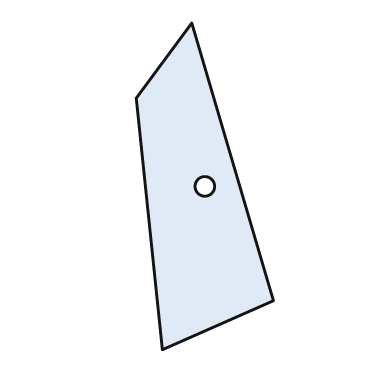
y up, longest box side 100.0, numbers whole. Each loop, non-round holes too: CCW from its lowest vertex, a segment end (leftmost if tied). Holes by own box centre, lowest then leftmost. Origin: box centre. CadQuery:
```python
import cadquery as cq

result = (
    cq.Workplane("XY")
    .moveTo(-13.0, -50.0)
    .lineTo(21.0, -35.0)
    .lineTo(-4.0, 50.0)
    .lineTo(-21.0, 27.0)
    .close()
    .moveTo(0.0, 0.0)
    .circle(3.0)
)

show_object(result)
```